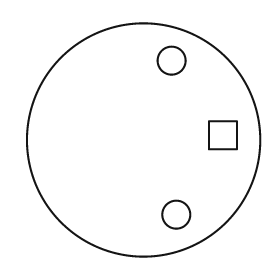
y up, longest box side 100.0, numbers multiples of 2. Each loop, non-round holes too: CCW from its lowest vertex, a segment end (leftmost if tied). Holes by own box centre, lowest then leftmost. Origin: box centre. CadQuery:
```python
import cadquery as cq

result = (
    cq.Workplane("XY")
    .moveTo(0.0, 0.0)
    .circle(50.0)
    .moveTo(14.0, -32.0)
    .circle(6.0)
    .moveTo(28.0, -4.0)
    .lineTo(40.0, -4.0)
    .lineTo(40.0, 8.0)
    .lineTo(28.0, 8.0)
    .close()
    .moveTo(12.0, 34.0)
    .circle(6.0)
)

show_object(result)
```